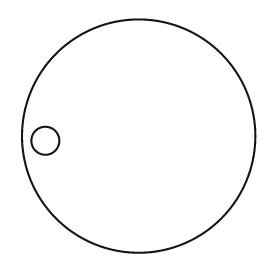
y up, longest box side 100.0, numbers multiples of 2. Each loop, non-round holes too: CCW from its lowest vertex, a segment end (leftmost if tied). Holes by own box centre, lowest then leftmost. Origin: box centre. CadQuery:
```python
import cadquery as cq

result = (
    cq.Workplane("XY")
    .moveTo(0.0, 0.0)
    .circle(50.0)
    .moveTo(-40.0, -2.0)
    .circle(6.0)
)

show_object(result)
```